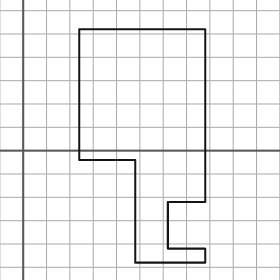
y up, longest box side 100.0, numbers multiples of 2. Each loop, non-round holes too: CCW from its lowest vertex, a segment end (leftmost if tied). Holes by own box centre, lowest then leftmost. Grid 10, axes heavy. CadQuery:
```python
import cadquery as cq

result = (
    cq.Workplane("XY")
    .moveTo(48.0, -48.0)
    .lineTo(78.0, -48.0)
    .lineTo(78.0, -42.0)
    .lineTo(62.0, -42.0)
    .lineTo(62.0, -22.0)
    .lineTo(78.0, -22.0)
    .lineTo(78.0, 52.0)
    .lineTo(24.0, 52.0)
    .lineTo(24.0, -4.0)
    .lineTo(48.0, -4.0)
    .close()
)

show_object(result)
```